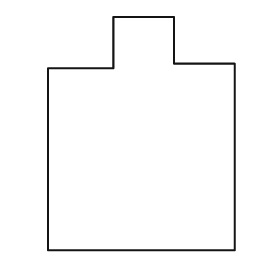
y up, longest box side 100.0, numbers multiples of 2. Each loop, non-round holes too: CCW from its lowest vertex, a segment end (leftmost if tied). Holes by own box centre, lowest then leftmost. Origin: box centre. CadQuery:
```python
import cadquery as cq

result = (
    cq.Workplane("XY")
    .moveTo(-40.0, -50.0)
    .lineTo(40.0, -50.0)
    .lineTo(40.0, 30.0)
    .lineTo(14.0, 30.0)
    .lineTo(14.0, 50.0)
    .lineTo(-12.0, 50.0)
    .lineTo(-12.0, 28.0)
    .lineTo(-40.0, 28.0)
    .close()
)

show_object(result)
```